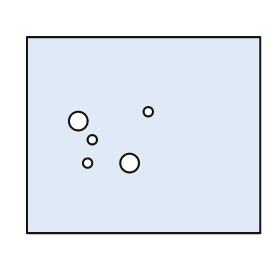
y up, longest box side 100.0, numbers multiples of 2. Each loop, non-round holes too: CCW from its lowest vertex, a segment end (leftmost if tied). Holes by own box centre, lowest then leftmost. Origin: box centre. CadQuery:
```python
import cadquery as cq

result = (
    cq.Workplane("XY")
    .moveTo(-50.0, -42.0)
    .lineTo(50.0, -42.0)
    .lineTo(50.0, 42.0)
    .lineTo(-50.0, 42.0)
    .close()
    .moveTo(-24.0, -12.0)
    .circle(2.0)
    .moveTo(-6.0, -12.0)
    .circle(4.0)
    .moveTo(-22.0, -2.0)
    .circle(2.0)
    .moveTo(-28.0, 6.0)
    .circle(4.0)
    .moveTo(2.0, 10.0)
    .circle(2.0)
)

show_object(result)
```